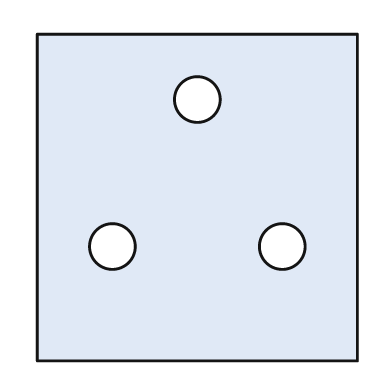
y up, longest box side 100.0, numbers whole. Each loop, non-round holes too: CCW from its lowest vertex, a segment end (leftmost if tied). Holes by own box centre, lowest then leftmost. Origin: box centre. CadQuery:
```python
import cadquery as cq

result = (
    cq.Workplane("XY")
    .moveTo(-49.0, -50.0)
    .lineTo(49.0, -50.0)
    .lineTo(49.0, 50.0)
    .lineTo(-49.0, 50.0)
    .close()
    .moveTo(-26.0, -15.0)
    .circle(7.0)
    .moveTo(26.0, -15.0)
    .circle(7.0)
    .moveTo(0.0, 30.0)
    .circle(7.0)
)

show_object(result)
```